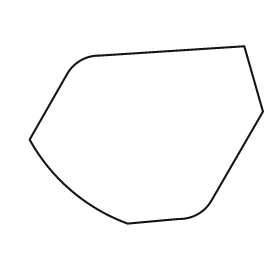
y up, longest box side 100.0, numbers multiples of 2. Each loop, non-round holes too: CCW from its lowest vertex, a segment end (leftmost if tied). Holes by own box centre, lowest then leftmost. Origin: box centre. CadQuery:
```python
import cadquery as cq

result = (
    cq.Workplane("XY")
    .moveTo(-8.0, -38.0)
    .lineTo(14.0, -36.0)
    .threePointArc((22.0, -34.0), (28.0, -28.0))
    .lineTo(50.0, 10.0)
    .lineTo(42.0, 38.0)
    .lineTo(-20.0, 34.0)
    .threePointArc((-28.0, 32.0), (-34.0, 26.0))
    .lineTo(-50.0, -2.0)
    .threePointArc((-32.0, -24.0), (-8.0, -38.0))
    .close()
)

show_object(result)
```